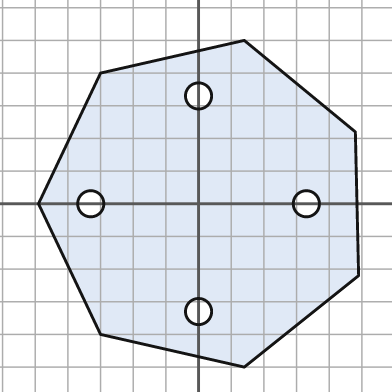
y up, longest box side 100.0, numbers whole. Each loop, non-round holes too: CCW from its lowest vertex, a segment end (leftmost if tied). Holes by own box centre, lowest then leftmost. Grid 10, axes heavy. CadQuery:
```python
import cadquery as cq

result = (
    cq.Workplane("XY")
    .moveTo(14.0, -50.0)
    .lineTo(49.0, -22.0)
    .lineTo(48.0, 22.0)
    .lineTo(14.0, 50.0)
    .lineTo(-30.0, 40.0)
    .lineTo(-49.0, 0.0)
    .lineTo(-30.0, -40.0)
    .close()
    .moveTo(0.0, -33.0)
    .circle(4.0)
    .moveTo(-33.0, 0.0)
    .circle(4.0)
    .moveTo(33.0, 0.0)
    .circle(4.0)
    .moveTo(0.0, 33.0)
    .circle(4.0)
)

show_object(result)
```